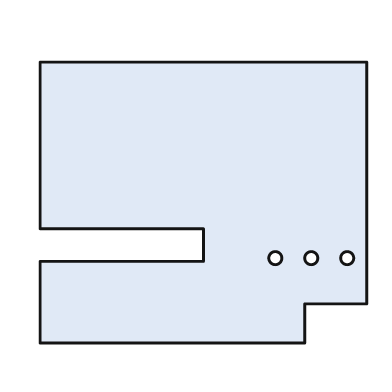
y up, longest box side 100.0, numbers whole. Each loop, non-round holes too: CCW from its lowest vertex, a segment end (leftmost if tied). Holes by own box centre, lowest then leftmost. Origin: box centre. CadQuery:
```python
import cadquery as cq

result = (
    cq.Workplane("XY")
    .moveTo(-50.0, -43.0)
    .lineTo(31.0, -43.0)
    .lineTo(31.0, -31.0)
    .lineTo(50.0, -31.0)
    .lineTo(50.0, 43.0)
    .lineTo(-50.0, 43.0)
    .lineTo(-50.0, -8.0)
    .lineTo(0.0, -8.0)
    .lineTo(0.0, -18.0)
    .lineTo(-50.0, -18.0)
    .close()
    .moveTo(22.0, -17.0)
    .circle(2.0)
    .moveTo(33.0, -17.0)
    .circle(2.0)
    .moveTo(44.0, -17.0)
    .circle(2.0)
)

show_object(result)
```